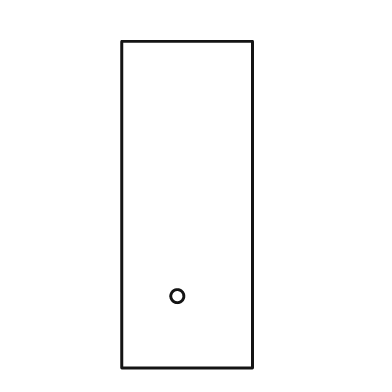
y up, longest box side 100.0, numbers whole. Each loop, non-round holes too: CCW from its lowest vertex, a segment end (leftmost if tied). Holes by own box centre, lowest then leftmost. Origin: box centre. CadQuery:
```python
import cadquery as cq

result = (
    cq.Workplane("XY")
    .moveTo(-20.0, -50.0)
    .lineTo(20.0, -50.0)
    .lineTo(20.0, 50.0)
    .lineTo(-20.0, 50.0)
    .close()
    .moveTo(-3.0, -28.0)
    .circle(2.0)
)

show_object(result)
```